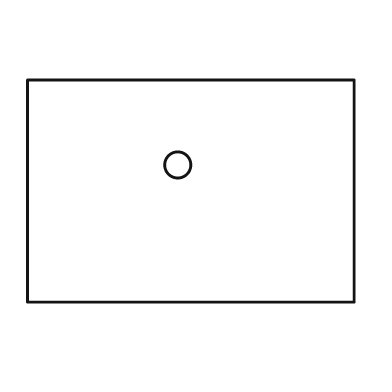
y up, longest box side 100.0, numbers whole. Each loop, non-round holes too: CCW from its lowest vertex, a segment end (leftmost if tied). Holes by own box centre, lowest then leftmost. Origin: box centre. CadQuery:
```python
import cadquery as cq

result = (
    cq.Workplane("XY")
    .moveTo(-50.0, -34.0)
    .lineTo(50.0, -34.0)
    .lineTo(50.0, 34.0)
    .lineTo(-50.0, 34.0)
    .close()
    .moveTo(-4.0, 8.0)
    .circle(4.0)
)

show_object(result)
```